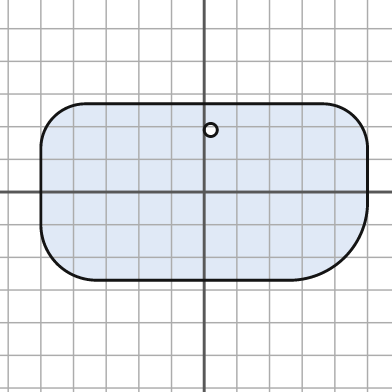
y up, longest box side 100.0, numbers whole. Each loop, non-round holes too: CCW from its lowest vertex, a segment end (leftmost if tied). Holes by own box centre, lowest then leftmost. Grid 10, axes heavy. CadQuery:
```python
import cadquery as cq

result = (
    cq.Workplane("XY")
    .moveTo(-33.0, -27.0)
    .lineTo(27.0, -27.0)
    .threePointArc((43.0, -20.0), (50.0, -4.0))
    .lineTo(50.0, 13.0)
    .threePointArc((46.0, 23.0), (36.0, 27.0))
    .lineTo(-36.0, 27.0)
    .threePointArc((-46.0, 23.0), (-50.0, 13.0))
    .lineTo(-50.0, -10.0)
    .threePointArc((-45.0, -22.0), (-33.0, -27.0))
    .close()
    .moveTo(2.0, 19.0)
    .circle(2.0)
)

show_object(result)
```